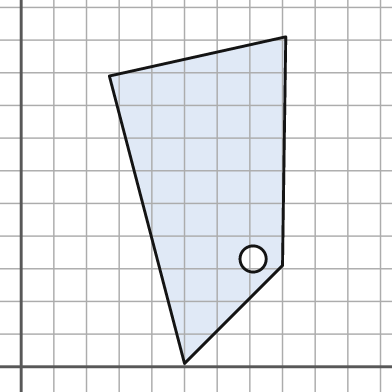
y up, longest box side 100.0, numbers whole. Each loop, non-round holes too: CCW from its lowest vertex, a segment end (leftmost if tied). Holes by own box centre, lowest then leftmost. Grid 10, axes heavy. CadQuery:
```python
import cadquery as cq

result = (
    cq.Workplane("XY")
    .moveTo(50.0, 1.0)
    .lineTo(80.0, 31.0)
    .lineTo(81.0, 101.0)
    .lineTo(27.0, 89.0)
    .close()
    .moveTo(71.0, 33.0)
    .circle(4.0)
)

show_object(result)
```